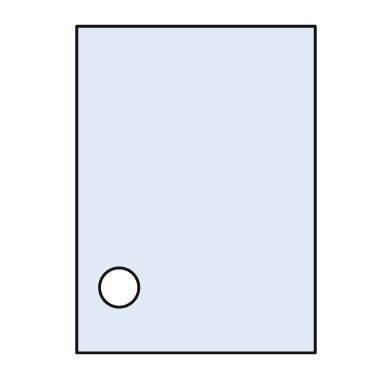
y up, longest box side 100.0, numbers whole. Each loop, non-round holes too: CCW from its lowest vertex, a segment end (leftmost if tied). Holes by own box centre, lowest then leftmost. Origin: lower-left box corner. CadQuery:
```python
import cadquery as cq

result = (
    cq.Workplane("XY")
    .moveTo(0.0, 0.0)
    .lineTo(73.0, 0.0)
    .lineTo(73.0, 100.0)
    .lineTo(0.0, 100.0)
    .close()
    .moveTo(13.0, 20.0)
    .circle(6.0)
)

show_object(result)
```